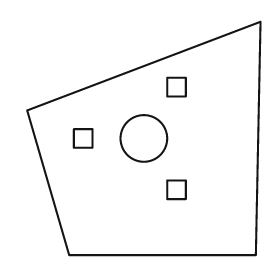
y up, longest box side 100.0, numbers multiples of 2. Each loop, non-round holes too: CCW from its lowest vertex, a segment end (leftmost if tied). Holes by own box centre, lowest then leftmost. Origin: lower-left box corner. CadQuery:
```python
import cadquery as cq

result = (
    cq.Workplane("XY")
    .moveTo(18.0, 0.0)
    .lineTo(98.0, 0.0)
    .lineTo(100.0, 100.0)
    .lineTo(0.0, 62.0)
    .close()
    .moveTo(60.0, 24.0)
    .lineTo(68.0, 24.0)
    .lineTo(68.0, 32.0)
    .lineTo(60.0, 32.0)
    .close()
    .moveTo(20.0, 46.0)
    .lineTo(28.0, 46.0)
    .lineTo(28.0, 54.0)
    .lineTo(20.0, 54.0)
    .close()
    .moveTo(50.0, 50.0)
    .circle(10.0)
    .moveTo(60.0, 68.0)
    .lineTo(68.0, 68.0)
    .lineTo(68.0, 76.0)
    .lineTo(60.0, 76.0)
    .close()
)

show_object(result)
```